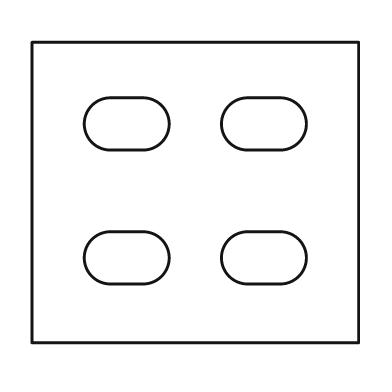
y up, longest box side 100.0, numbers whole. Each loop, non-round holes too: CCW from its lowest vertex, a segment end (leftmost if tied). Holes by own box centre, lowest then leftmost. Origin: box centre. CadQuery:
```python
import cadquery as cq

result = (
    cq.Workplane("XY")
    .moveTo(-50.0, -46.0)
    .lineTo(50.0, -46.0)
    .lineTo(50.0, 46.0)
    .lineTo(-50.0, 46.0)
    .close()
    .moveTo(-26.0, -28.0)
    .lineTo(-16.0, -28.0)
    .threePointArc((-8.0, -20.0), (-16.0, -12.0))
    .lineTo(-26.0, -12.0)
    .threePointArc((-34.0, -20.0), (-26.0, -28.0))
    .close()
    .moveTo(16.0, -28.0)
    .lineTo(26.0, -28.0)
    .threePointArc((34.0, -20.0), (26.0, -12.0))
    .lineTo(16.0, -12.0)
    .threePointArc((8.0, -20.0), (16.0, -28.0))
    .close()
    .moveTo(-26.0, 13.0)
    .lineTo(-16.0, 13.0)
    .threePointArc((-8.0, 21.0), (-16.0, 29.0))
    .lineTo(-26.0, 29.0)
    .threePointArc((-34.0, 21.0), (-26.0, 13.0))
    .close()
    .moveTo(16.0, 13.0)
    .lineTo(26.0, 13.0)
    .threePointArc((34.0, 21.0), (26.0, 29.0))
    .lineTo(16.0, 29.0)
    .threePointArc((8.0, 21.0), (16.0, 13.0))
    .close()
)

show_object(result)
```